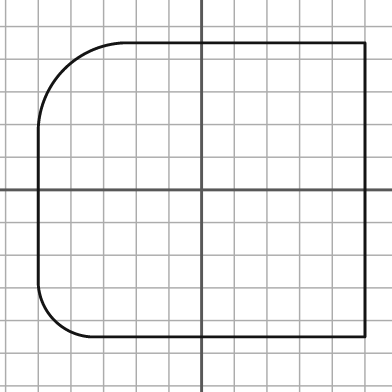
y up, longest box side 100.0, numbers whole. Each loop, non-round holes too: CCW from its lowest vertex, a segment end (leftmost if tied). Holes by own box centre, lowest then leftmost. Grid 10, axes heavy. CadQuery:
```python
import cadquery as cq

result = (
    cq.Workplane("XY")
    .moveTo(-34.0, -45.0)
    .lineTo(50.0, -45.0)
    .lineTo(50.0, 45.0)
    .lineTo(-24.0, 45.0)
    .threePointArc((-42.0, 37.0), (-50.0, 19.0))
    .lineTo(-50.0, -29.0)
    .threePointArc((-45.0, -40.0), (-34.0, -45.0))
    .close()
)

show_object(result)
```